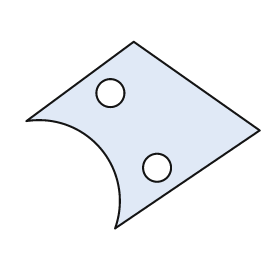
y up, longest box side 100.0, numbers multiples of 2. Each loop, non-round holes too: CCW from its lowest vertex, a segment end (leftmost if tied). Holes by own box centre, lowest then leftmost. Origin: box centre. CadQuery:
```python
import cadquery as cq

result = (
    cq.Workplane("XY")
    .moveTo(-12.0, -40.0)
    .lineTo(50.0, 2.0)
    .lineTo(-4.0, 40.0)
    .lineTo(-50.0, 6.0)
    .threePointArc((-18.0, -6.0), (-12.0, -40.0))
    .close()
    .moveTo(6.0, -14.0)
    .circle(6.0)
    .moveTo(-14.0, 18.0)
    .circle(6.0)
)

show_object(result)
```